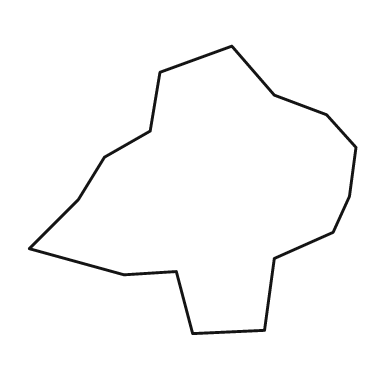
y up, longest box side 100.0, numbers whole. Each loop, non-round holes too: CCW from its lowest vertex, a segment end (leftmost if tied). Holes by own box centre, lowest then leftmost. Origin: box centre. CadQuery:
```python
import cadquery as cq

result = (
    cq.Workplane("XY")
    .moveTo(0.0, -44.0)
    .lineTo(22.0, -43.0)
    .lineTo(25.0, -21.0)
    .lineTo(43.0, -13.0)
    .lineTo(48.0, -2.0)
    .lineTo(50.0, 13.0)
    .lineTo(41.0, 23.0)
    .lineTo(25.0, 29.0)
    .lineTo(12.0, 44.0)
    .lineTo(-10.0, 36.0)
    .lineTo(-13.0, 18.0)
    .lineTo(-27.0, 10.0)
    .lineTo(-35.0, -3.0)
    .lineTo(-50.0, -18.0)
    .lineTo(-21.0, -26.0)
    .lineTo(-5.0, -25.0)
    .close()
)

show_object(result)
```